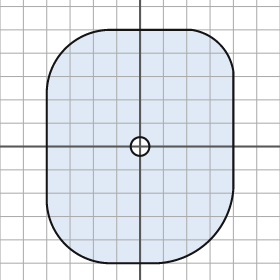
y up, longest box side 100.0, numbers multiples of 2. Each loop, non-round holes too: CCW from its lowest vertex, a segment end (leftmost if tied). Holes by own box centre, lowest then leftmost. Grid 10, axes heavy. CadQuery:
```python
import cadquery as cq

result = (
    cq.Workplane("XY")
    .moveTo(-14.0, -50.0)
    .lineTo(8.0, -50.0)
    .threePointArc((30.0, -40.0), (40.0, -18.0))
    .lineTo(40.0, 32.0)
    .threePointArc((34.0, 44.0), (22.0, 50.0))
    .lineTo(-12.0, 50.0)
    .threePointArc((-32.0, 42.0), (-40.0, 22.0))
    .lineTo(-40.0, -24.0)
    .threePointArc((-32.0, -42.0), (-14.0, -50.0))
    .close()
    .moveTo(0.0, 0.0)
    .circle(4.0)
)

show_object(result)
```